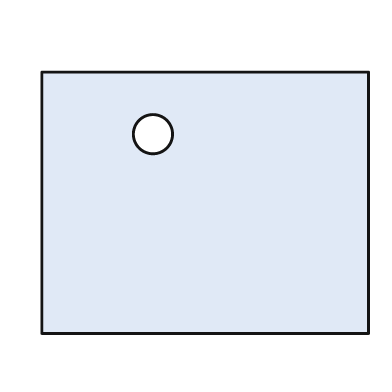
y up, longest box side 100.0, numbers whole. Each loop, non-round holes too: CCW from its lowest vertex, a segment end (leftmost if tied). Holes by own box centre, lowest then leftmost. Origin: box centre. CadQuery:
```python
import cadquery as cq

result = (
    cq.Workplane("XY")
    .moveTo(-50.0, -40.0)
    .lineTo(50.0, -40.0)
    .lineTo(50.0, 40.0)
    .lineTo(-50.0, 40.0)
    .close()
    .moveTo(-16.0, 21.0)
    .circle(6.0)
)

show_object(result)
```